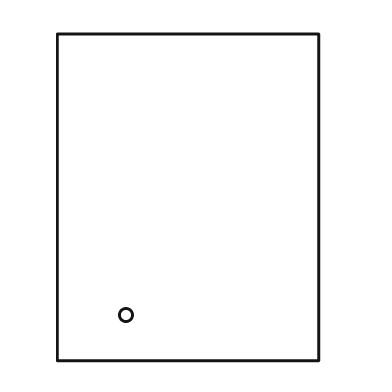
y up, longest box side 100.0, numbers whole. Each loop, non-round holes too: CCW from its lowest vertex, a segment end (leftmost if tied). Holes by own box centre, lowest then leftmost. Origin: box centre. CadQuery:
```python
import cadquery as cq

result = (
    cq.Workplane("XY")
    .moveTo(-40.0, -50.0)
    .lineTo(40.0, -50.0)
    .lineTo(40.0, 50.0)
    .lineTo(-40.0, 50.0)
    .close()
    .moveTo(-19.0, -36.0)
    .circle(2.0)
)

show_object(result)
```